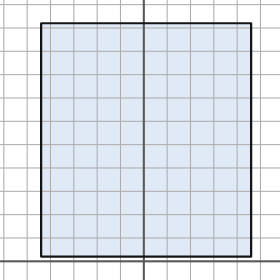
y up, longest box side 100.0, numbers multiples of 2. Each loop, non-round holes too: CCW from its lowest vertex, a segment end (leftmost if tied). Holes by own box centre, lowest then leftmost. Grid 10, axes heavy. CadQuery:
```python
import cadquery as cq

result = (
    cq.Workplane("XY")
    .moveTo(-44.0, 2.0)
    .lineTo(46.0, 2.0)
    .lineTo(46.0, 102.0)
    .lineTo(-44.0, 102.0)
    .close()
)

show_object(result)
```